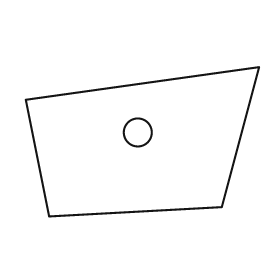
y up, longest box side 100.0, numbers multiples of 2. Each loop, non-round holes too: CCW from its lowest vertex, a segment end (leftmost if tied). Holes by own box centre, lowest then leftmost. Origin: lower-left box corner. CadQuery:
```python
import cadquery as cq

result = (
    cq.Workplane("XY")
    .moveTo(10.0, 0.0)
    .lineTo(84.0, 4.0)
    .lineTo(100.0, 64.0)
    .lineTo(0.0, 50.0)
    .close()
    .moveTo(48.0, 36.0)
    .circle(6.0)
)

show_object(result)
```